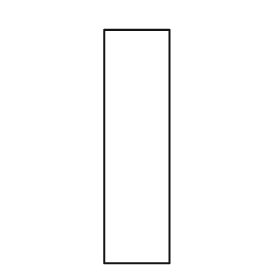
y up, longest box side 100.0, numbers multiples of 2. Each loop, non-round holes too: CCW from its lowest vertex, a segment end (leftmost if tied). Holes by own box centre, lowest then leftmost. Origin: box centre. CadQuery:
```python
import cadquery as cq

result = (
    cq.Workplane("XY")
    .moveTo(-14.0, -50.0)
    .lineTo(14.0, -50.0)
    .lineTo(14.0, 50.0)
    .lineTo(-14.0, 50.0)
    .close()
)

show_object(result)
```